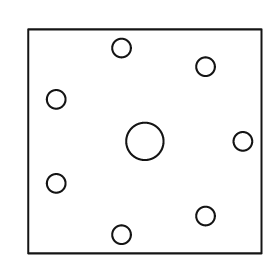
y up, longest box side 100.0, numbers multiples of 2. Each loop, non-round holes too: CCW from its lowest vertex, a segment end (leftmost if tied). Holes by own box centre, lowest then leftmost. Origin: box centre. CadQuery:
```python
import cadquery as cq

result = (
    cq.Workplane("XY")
    .moveTo(-50.0, -48.0)
    .lineTo(50.0, -48.0)
    .lineTo(50.0, 48.0)
    .lineTo(-50.0, 48.0)
    .close()
    .moveTo(-10.0, -40.0)
    .circle(4.0)
    .moveTo(26.0, -32.0)
    .circle(4.0)
    .moveTo(-38.0, -18.0)
    .circle(4.0)
    .moveTo(0.0, 0.0)
    .circle(8.0)
    .moveTo(42.0, 0.0)
    .circle(4.0)
    .moveTo(-38.0, 18.0)
    .circle(4.0)
    .moveTo(26.0, 32.0)
    .circle(4.0)
    .moveTo(-10.0, 40.0)
    .circle(4.0)
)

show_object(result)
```